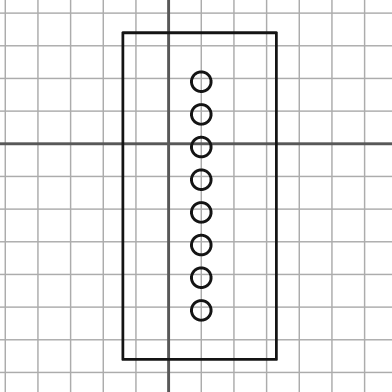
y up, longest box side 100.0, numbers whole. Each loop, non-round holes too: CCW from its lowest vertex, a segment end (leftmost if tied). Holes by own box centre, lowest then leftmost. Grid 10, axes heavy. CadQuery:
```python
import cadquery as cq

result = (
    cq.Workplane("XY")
    .moveTo(-14.0, -66.0)
    .lineTo(33.0, -66.0)
    .lineTo(33.0, 34.0)
    .lineTo(-14.0, 34.0)
    .close()
    .moveTo(10.0, -51.0)
    .circle(3.0)
    .moveTo(10.0, -41.0)
    .circle(3.0)
    .moveTo(10.0, -31.0)
    .circle(3.0)
    .moveTo(10.0, -21.0)
    .circle(3.0)
    .moveTo(10.0, -11.0)
    .circle(3.0)
    .moveTo(10.0, -1.0)
    .circle(3.0)
    .moveTo(10.0, 9.0)
    .circle(3.0)
    .moveTo(10.0, 19.0)
    .circle(3.0)
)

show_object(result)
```